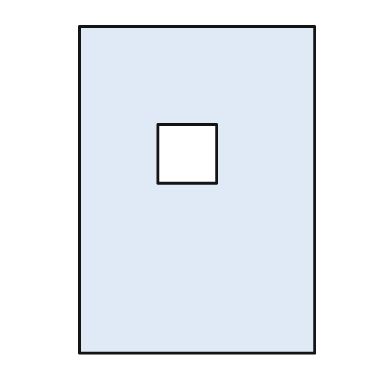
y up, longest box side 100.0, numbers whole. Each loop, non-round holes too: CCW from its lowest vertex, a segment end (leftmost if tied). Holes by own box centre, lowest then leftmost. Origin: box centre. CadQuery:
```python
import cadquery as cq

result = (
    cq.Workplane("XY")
    .moveTo(-36.0, -50.0)
    .lineTo(36.0, -50.0)
    .lineTo(36.0, 50.0)
    .lineTo(-36.0, 50.0)
    .close()
    .moveTo(-12.0, 2.0)
    .lineTo(6.0, 2.0)
    .lineTo(6.0, 20.0)
    .lineTo(-12.0, 20.0)
    .close()
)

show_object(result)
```